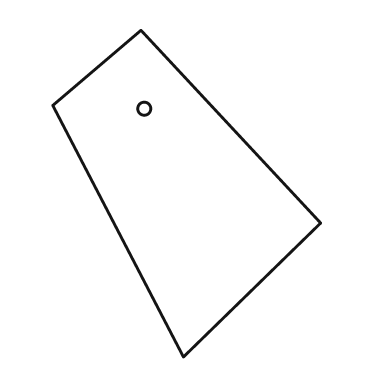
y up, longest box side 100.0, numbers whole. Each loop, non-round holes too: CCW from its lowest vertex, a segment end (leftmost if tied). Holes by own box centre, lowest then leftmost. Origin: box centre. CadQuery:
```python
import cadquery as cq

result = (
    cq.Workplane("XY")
    .moveTo(-1.0, -50.0)
    .lineTo(41.0, -9.0)
    .lineTo(-14.0, 50.0)
    .lineTo(-41.0, 27.0)
    .close()
    .moveTo(-13.0, 26.0)
    .circle(2.0)
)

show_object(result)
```